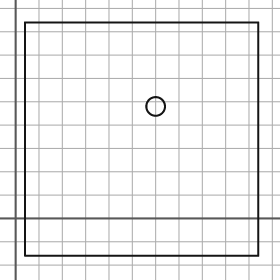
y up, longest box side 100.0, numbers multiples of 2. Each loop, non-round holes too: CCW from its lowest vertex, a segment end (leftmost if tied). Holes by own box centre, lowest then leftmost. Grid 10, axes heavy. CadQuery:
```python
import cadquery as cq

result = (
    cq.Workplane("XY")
    .moveTo(4.0, -16.0)
    .lineTo(104.0, -16.0)
    .lineTo(104.0, 84.0)
    .lineTo(4.0, 84.0)
    .close()
    .moveTo(60.0, 48.0)
    .circle(4.0)
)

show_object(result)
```